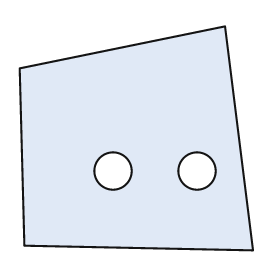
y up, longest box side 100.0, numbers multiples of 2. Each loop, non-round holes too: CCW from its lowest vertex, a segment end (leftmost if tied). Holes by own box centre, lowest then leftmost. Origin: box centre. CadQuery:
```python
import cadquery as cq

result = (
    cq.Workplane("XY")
    .moveTo(50.0, -48.0)
    .lineTo(38.0, 48.0)
    .lineTo(-50.0, 30.0)
    .lineTo(-48.0, -46.0)
    .close()
    .moveTo(-10.0, -14.0)
    .circle(8.0)
    .moveTo(26.0, -14.0)
    .circle(8.0)
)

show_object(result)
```